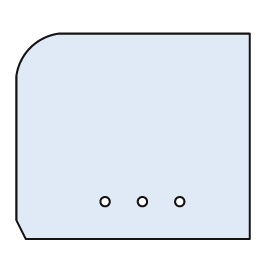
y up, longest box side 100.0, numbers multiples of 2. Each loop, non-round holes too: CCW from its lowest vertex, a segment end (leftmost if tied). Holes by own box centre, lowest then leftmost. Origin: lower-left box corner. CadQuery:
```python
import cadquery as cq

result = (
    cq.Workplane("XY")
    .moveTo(4.0, 0.0)
    .lineTo(100.0, 0.0)
    .lineTo(100.0, 88.0)
    .lineTo(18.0, 88.0)
    .threePointArc((6.0, 82.0), (0.0, 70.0))
    .lineTo(0.0, 8.0)
    .close()
    .moveTo(38.0, 16.0)
    .circle(2.0)
    .moveTo(54.0, 16.0)
    .circle(2.0)
    .moveTo(70.0, 16.0)
    .circle(2.0)
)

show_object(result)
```